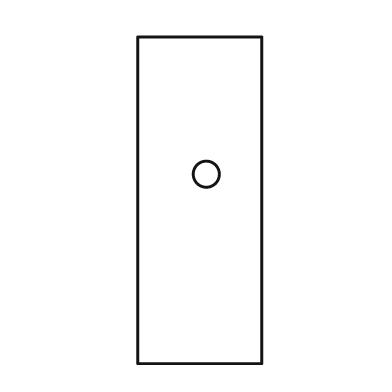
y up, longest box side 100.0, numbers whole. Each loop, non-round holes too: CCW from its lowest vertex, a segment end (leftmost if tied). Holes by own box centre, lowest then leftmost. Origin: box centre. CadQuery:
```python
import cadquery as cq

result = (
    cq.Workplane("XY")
    .moveTo(-19.0, -50.0)
    .lineTo(19.0, -50.0)
    .lineTo(19.0, 50.0)
    .lineTo(-19.0, 50.0)
    .close()
    .moveTo(2.0, 8.0)
    .circle(4.0)
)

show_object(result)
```